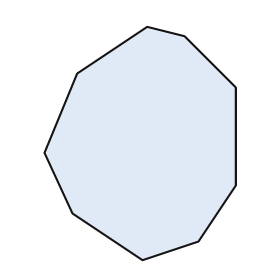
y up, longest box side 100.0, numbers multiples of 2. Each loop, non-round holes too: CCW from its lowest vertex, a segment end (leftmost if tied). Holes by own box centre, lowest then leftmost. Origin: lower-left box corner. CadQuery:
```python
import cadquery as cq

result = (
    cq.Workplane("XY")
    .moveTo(42.0, 0.0)
    .lineTo(66.0, 8.0)
    .lineTo(82.0, 32.0)
    .lineTo(82.0, 74.0)
    .lineTo(60.0, 96.0)
    .lineTo(44.0, 100.0)
    .lineTo(14.0, 80.0)
    .lineTo(0.0, 46.0)
    .lineTo(12.0, 20.0)
    .close()
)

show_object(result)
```